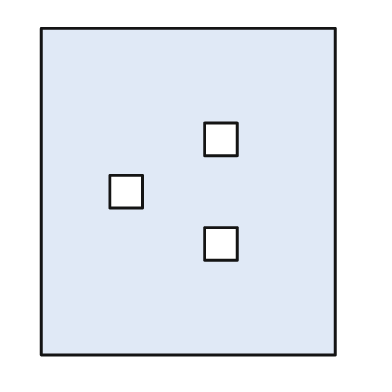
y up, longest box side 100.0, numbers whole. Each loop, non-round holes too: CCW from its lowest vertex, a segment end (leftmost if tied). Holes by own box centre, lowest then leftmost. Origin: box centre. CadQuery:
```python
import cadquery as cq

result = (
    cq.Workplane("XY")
    .moveTo(-45.0, -50.0)
    .lineTo(45.0, -50.0)
    .lineTo(45.0, 50.0)
    .lineTo(-45.0, 50.0)
    .close()
    .moveTo(5.0, -21.0)
    .lineTo(15.0, -21.0)
    .lineTo(15.0, -11.0)
    .lineTo(5.0, -11.0)
    .close()
    .moveTo(-24.0, -5.0)
    .lineTo(-14.0, -5.0)
    .lineTo(-14.0, 5.0)
    .lineTo(-24.0, 5.0)
    .close()
    .moveTo(5.0, 11.0)
    .lineTo(15.0, 11.0)
    .lineTo(15.0, 21.0)
    .lineTo(5.0, 21.0)
    .close()
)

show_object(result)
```